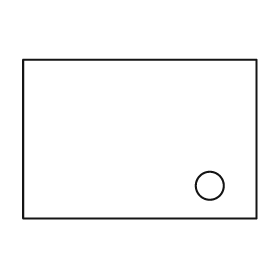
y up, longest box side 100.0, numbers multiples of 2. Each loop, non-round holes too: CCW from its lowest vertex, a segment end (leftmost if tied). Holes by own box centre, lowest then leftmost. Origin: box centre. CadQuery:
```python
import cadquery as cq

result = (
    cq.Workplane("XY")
    .moveTo(-50.0, -34.0)
    .lineTo(50.0, -34.0)
    .lineTo(50.0, 34.0)
    .lineTo(-50.0, 34.0)
    .close()
    .moveTo(30.0, -20.0)
    .circle(6.0)
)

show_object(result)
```